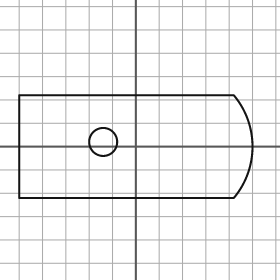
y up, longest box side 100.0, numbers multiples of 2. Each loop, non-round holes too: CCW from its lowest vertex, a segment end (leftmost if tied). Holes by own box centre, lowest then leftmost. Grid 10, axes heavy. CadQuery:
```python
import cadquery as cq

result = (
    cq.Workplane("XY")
    .moveTo(-50.0, -22.0)
    .lineTo(42.0, -22.0)
    .threePointArc((50.0, 0.0), (42.0, 22.0))
    .lineTo(-50.0, 22.0)
    .close()
    .moveTo(-14.0, 2.0)
    .circle(6.0)
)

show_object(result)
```